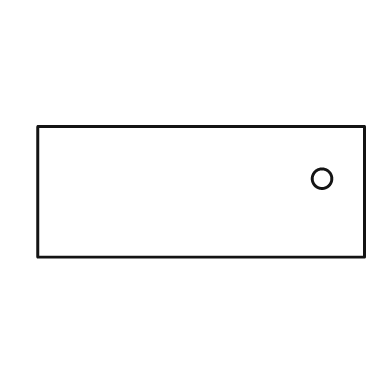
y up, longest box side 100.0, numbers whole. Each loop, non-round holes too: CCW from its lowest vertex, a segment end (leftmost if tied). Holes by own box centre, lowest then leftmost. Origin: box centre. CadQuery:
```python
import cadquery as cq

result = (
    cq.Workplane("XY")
    .moveTo(-50.0, -20.0)
    .lineTo(50.0, -20.0)
    .lineTo(50.0, 20.0)
    .lineTo(-50.0, 20.0)
    .close()
    .moveTo(37.0, 4.0)
    .circle(3.0)
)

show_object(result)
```